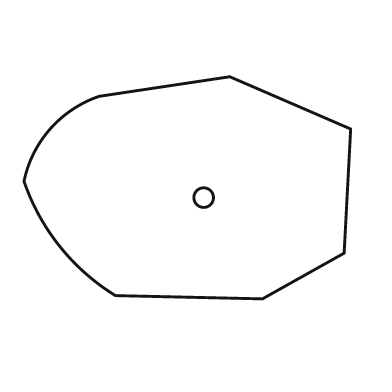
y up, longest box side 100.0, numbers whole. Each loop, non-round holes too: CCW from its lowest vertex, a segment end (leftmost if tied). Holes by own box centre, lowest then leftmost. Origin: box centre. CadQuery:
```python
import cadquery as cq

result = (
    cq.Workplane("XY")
    .moveTo(23.0, -34.0)
    .lineTo(48.0, -20.0)
    .lineTo(50.0, 18.0)
    .lineTo(13.0, 34.0)
    .lineTo(-27.0, 28.0)
    .threePointArc((-42.0, 18.0), (-50.0, 2.0))
    .threePointArc((-39.0, -18.0), (-22.0, -33.0))
    .close()
    .moveTo(5.0, -3.0)
    .circle(3.0)
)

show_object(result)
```